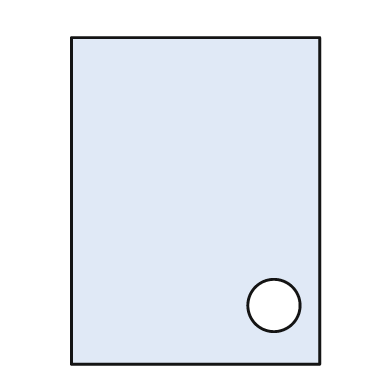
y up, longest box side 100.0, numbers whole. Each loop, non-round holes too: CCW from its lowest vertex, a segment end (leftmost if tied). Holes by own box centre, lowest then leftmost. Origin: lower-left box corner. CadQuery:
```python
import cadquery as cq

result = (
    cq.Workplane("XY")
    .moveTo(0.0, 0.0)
    .lineTo(76.0, 0.0)
    .lineTo(76.0, 100.0)
    .lineTo(0.0, 100.0)
    .close()
    .moveTo(62.0, 18.0)
    .circle(8.0)
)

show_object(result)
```